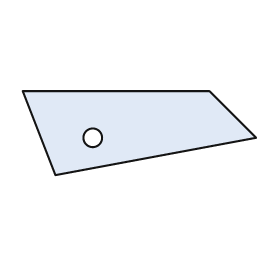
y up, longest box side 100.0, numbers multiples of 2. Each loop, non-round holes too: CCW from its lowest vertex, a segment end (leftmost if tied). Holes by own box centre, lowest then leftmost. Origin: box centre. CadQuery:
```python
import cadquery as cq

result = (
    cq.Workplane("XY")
    .moveTo(-36.0, -18.0)
    .lineTo(50.0, -2.0)
    .lineTo(30.0, 18.0)
    .lineTo(-50.0, 18.0)
    .close()
    .moveTo(-20.0, -2.0)
    .circle(4.0)
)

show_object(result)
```